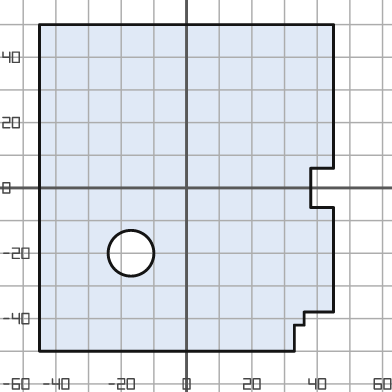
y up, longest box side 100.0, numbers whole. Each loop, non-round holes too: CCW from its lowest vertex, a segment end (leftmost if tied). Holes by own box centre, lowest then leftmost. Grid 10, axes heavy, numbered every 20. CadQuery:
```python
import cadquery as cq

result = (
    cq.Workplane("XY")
    .moveTo(-45.0, -50.0)
    .lineTo(33.0, -50.0)
    .lineTo(33.0, -42.0)
    .lineTo(36.0, -42.0)
    .lineTo(36.0, -38.0)
    .lineTo(45.0, -38.0)
    .lineTo(45.0, -6.0)
    .lineTo(38.0, -6.0)
    .lineTo(38.0, 6.0)
    .lineTo(45.0, 6.0)
    .lineTo(45.0, 50.0)
    .lineTo(-45.0, 50.0)
    .close()
    .moveTo(-17.0, -20.0)
    .circle(7.0)
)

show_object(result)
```